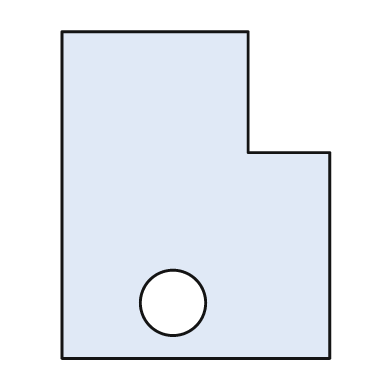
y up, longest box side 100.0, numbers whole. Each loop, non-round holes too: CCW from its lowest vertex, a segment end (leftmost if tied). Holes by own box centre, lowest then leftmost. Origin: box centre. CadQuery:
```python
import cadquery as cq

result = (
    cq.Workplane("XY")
    .moveTo(-41.0, -50.0)
    .lineTo(41.0, -50.0)
    .lineTo(41.0, 13.0)
    .lineTo(16.0, 13.0)
    .lineTo(16.0, 50.0)
    .lineTo(-41.0, 50.0)
    .close()
    .moveTo(-7.0, -33.0)
    .circle(10.0)
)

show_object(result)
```